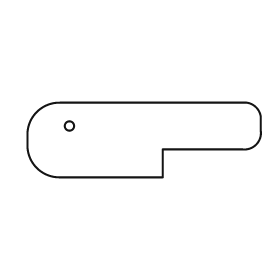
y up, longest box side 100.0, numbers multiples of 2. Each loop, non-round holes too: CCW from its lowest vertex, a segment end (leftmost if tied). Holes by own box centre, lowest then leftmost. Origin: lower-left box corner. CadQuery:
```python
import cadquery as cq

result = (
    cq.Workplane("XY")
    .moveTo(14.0, 0.0)
    .lineTo(58.0, 0.0)
    .lineTo(58.0, 12.0)
    .lineTo(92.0, 12.0)
    .threePointArc((98.0, 14.0), (100.0, 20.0))
    .lineTo(100.0, 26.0)
    .threePointArc((98.0, 30.0), (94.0, 32.0))
    .lineTo(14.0, 32.0)
    .threePointArc((4.0, 28.0), (0.0, 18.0))
    .lineTo(0.0, 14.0)
    .threePointArc((4.0, 4.0), (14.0, 0.0))
    .close()
    .moveTo(18.0, 22.0)
    .circle(2.0)
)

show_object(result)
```